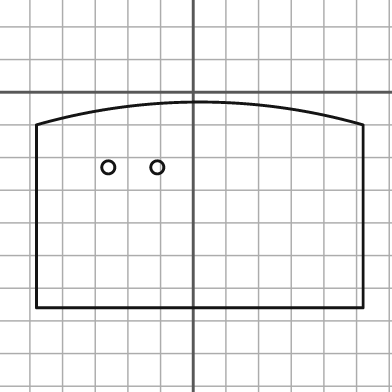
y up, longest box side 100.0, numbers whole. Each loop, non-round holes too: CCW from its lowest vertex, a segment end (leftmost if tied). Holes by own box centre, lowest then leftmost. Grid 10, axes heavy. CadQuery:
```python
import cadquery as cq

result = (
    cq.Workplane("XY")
    .moveTo(-48.0, -66.0)
    .lineTo(52.0, -66.0)
    .lineTo(52.0, -10.0)
    .threePointArc((2.0, -3.0), (-48.0, -10.0))
    .close()
    .moveTo(-26.0, -23.0)
    .circle(2.0)
    .moveTo(-11.0, -23.0)
    .circle(2.0)
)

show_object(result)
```